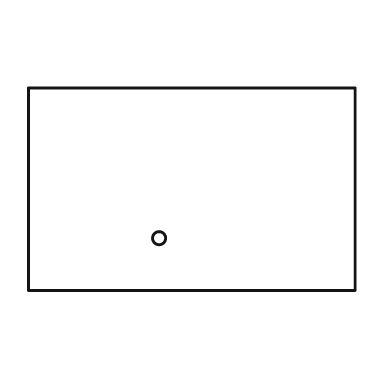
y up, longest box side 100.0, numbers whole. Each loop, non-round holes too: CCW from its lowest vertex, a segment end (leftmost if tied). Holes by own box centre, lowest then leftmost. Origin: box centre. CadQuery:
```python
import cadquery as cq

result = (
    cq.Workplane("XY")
    .moveTo(-50.0, -31.0)
    .lineTo(50.0, -31.0)
    .lineTo(50.0, 31.0)
    .lineTo(-50.0, 31.0)
    .close()
    .moveTo(-10.0, -15.0)
    .circle(2.0)
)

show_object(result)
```